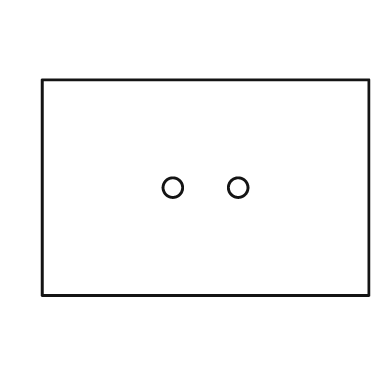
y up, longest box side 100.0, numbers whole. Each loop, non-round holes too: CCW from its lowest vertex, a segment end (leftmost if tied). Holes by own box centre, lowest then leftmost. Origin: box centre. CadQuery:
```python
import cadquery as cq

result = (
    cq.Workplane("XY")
    .moveTo(-50.0, -33.0)
    .lineTo(50.0, -33.0)
    .lineTo(50.0, 33.0)
    .lineTo(-50.0, 33.0)
    .close()
    .moveTo(-10.0, 0.0)
    .circle(3.0)
    .moveTo(10.0, 0.0)
    .circle(3.0)
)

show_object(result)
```